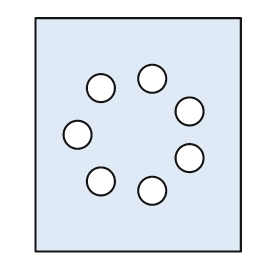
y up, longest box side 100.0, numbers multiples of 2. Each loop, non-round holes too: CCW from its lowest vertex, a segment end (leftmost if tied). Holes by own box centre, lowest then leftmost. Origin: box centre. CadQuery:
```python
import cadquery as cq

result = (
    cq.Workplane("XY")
    .moveTo(-44.0, -50.0)
    .lineTo(44.0, -50.0)
    .lineTo(44.0, 50.0)
    .lineTo(-44.0, 50.0)
    .close()
    .moveTo(6.0, -24.0)
    .circle(6.0)
    .moveTo(-16.0, -20.0)
    .circle(6.0)
    .moveTo(22.0, -10.0)
    .circle(6.0)
    .moveTo(-26.0, 0.0)
    .circle(6.0)
    .moveTo(22.0, 10.0)
    .circle(6.0)
    .moveTo(-16.0, 20.0)
    .circle(6.0)
    .moveTo(6.0, 24.0)
    .circle(6.0)
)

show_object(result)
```